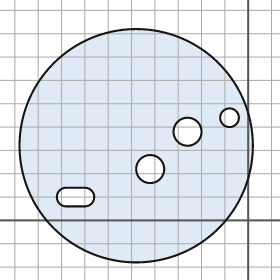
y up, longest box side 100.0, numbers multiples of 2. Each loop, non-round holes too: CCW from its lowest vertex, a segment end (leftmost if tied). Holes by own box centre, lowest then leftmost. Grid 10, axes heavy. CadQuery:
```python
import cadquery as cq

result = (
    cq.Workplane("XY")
    .moveTo(-48.0, 32.0)
    .circle(50.0)
    .moveTo(-78.0, 6.0)
    .lineTo(-70.0, 6.0)
    .threePointArc((-66.0, 10.0), (-70.0, 14.0))
    .lineTo(-78.0, 14.0)
    .threePointArc((-82.0, 10.0), (-78.0, 6.0))
    .close()
    .moveTo(-42.0, 22.0)
    .circle(6.0)
    .moveTo(-26.0, 38.0)
    .circle(6.0)
    .moveTo(-8.0, 44.0)
    .circle(4.0)
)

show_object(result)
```